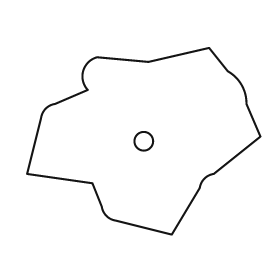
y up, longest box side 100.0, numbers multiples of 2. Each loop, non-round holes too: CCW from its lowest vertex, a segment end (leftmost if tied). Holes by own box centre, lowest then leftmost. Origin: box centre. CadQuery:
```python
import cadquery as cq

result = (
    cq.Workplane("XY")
    .moveTo(12.0, -40.0)
    .lineTo(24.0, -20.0)
    .threePointArc((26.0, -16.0), (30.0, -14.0))
    .lineTo(50.0, 2.0)
    .lineTo(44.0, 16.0)
    .threePointArc((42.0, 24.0), (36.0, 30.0))
    .lineTo(28.0, 40.0)
    .lineTo(2.0, 34.0)
    .lineTo(-20.0, 36.0)
    .threePointArc((-26.0, 30.0), (-24.0, 22.0))
    .lineTo(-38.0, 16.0)
    .threePointArc((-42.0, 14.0), (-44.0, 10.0))
    .lineTo(-50.0, -14.0)
    .lineTo(-22.0, -18.0)
    .lineTo(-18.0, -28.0)
    .threePointArc((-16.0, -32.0), (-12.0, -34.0))
    .close()
    .moveTo(0.0, 0.0)
    .circle(4.0)
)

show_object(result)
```